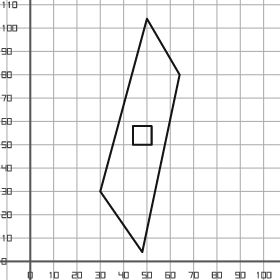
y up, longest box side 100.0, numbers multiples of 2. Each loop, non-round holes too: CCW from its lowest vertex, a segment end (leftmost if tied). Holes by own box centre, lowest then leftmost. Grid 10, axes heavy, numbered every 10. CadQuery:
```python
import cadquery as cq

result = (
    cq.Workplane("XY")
    .moveTo(48.0, 4.0)
    .lineTo(64.0, 80.0)
    .lineTo(50.0, 104.0)
    .lineTo(30.0, 30.0)
    .close()
    .moveTo(44.0, 50.0)
    .lineTo(52.0, 50.0)
    .lineTo(52.0, 58.0)
    .lineTo(44.0, 58.0)
    .close()
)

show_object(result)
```